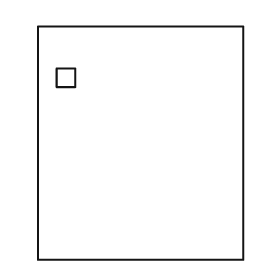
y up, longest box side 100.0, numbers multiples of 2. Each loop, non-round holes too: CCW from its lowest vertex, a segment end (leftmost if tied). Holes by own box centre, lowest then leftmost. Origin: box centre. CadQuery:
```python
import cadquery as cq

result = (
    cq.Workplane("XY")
    .moveTo(-44.0, -50.0)
    .lineTo(44.0, -50.0)
    .lineTo(44.0, 50.0)
    .lineTo(-44.0, 50.0)
    .close()
    .moveTo(-36.0, 24.0)
    .lineTo(-28.0, 24.0)
    .lineTo(-28.0, 32.0)
    .lineTo(-36.0, 32.0)
    .close()
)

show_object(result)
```